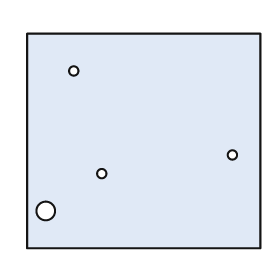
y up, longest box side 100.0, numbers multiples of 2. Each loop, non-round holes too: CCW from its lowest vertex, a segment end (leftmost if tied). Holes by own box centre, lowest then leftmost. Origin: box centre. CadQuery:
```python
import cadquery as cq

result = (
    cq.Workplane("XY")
    .moveTo(-50.0, -46.0)
    .lineTo(50.0, -46.0)
    .lineTo(50.0, 46.0)
    .lineTo(-50.0, 46.0)
    .close()
    .moveTo(-42.0, -30.0)
    .circle(4.0)
    .moveTo(-18.0, -14.0)
    .circle(2.0)
    .moveTo(38.0, -6.0)
    .circle(2.0)
    .moveTo(-30.0, 30.0)
    .circle(2.0)
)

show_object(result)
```